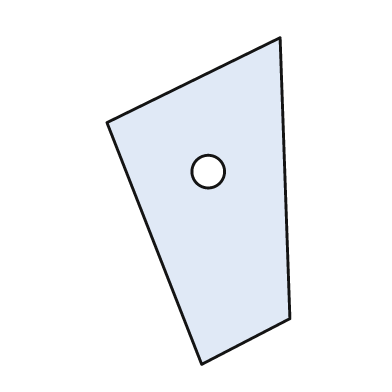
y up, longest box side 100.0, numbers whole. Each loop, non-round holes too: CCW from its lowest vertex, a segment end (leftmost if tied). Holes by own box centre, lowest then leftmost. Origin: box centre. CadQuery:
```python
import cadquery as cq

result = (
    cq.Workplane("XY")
    .moveTo(1.0, -50.0)
    .lineTo(28.0, -36.0)
    .lineTo(25.0, 50.0)
    .lineTo(-28.0, 24.0)
    .close()
    .moveTo(3.0, 9.0)
    .circle(5.0)
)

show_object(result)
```